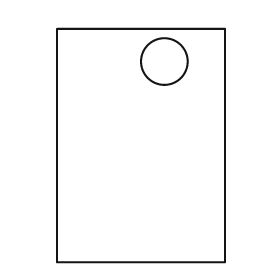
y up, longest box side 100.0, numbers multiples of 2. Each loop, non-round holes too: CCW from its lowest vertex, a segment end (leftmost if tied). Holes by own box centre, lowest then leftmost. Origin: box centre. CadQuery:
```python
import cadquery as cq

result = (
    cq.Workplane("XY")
    .moveTo(-36.0, -50.0)
    .lineTo(36.0, -50.0)
    .lineTo(36.0, 50.0)
    .lineTo(-36.0, 50.0)
    .close()
    .moveTo(10.0, 36.0)
    .circle(10.0)
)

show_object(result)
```